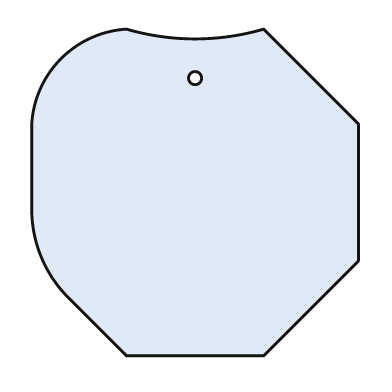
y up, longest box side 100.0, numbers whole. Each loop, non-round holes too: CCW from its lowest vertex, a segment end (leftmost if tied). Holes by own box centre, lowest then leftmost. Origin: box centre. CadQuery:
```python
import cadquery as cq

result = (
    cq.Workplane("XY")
    .moveTo(-21.0, -50.0)
    .lineTo(21.0, -50.0)
    .lineTo(50.0, -21.0)
    .lineTo(50.0, 21.0)
    .lineTo(21.0, 50.0)
    .threePointArc((0.0, 47.0), (-21.0, 50.0))
    .threePointArc((-41.0, 41.0), (-50.0, 21.0))
    .lineTo(-50.0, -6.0)
    .threePointArc((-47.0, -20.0), (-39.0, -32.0))
    .close()
    .moveTo(0.0, 35.0)
    .circle(2.0)
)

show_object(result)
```